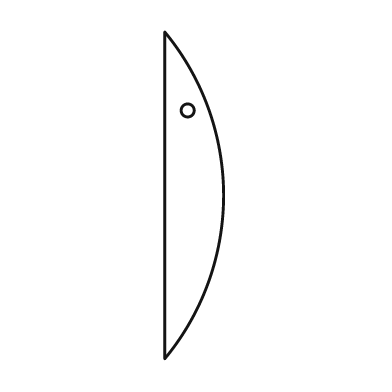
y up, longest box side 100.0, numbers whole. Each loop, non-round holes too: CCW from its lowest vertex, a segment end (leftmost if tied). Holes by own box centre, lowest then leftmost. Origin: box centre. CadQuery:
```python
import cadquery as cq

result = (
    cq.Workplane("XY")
    .moveTo(-9.0, -50.0)
    .threePointArc((9.0, 0.0), (-9.0, 50.0))
    .close()
    .moveTo(-2.0, 26.0)
    .circle(2.0)
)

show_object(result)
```